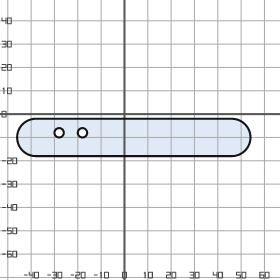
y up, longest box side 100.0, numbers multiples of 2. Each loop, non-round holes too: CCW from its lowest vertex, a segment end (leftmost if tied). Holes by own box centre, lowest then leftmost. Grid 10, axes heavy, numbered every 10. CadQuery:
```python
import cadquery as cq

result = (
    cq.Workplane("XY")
    .moveTo(-38.0, -18.0)
    .lineTo(46.0, -18.0)
    .threePointArc((54.0, -10.0), (46.0, -2.0))
    .lineTo(-38.0, -2.0)
    .threePointArc((-46.0, -10.0), (-38.0, -18.0))
    .close()
    .moveTo(-28.0, -8.0)
    .circle(2.0)
    .moveTo(-18.0, -8.0)
    .circle(2.0)
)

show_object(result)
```